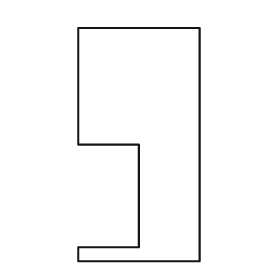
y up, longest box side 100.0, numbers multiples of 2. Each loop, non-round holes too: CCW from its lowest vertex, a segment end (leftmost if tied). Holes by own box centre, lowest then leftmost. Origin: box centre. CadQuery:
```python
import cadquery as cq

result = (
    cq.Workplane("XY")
    .moveTo(-26.0, -50.0)
    .lineTo(26.0, -50.0)
    .lineTo(26.0, 50.0)
    .lineTo(-26.0, 50.0)
    .lineTo(-26.0, 0.0)
    .lineTo(0.0, 0.0)
    .lineTo(0.0, -44.0)
    .lineTo(-26.0, -44.0)
    .close()
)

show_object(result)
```